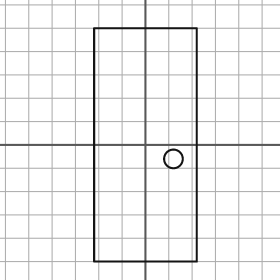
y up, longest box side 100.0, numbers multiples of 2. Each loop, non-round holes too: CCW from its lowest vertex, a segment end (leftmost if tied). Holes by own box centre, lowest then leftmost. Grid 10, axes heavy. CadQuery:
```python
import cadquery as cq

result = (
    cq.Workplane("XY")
    .moveTo(-22.0, -50.0)
    .lineTo(22.0, -50.0)
    .lineTo(22.0, 50.0)
    .lineTo(-22.0, 50.0)
    .close()
    .moveTo(12.0, -6.0)
    .circle(4.0)
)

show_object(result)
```